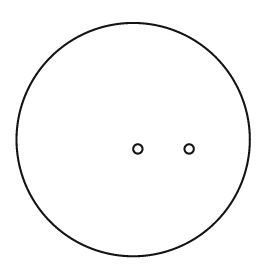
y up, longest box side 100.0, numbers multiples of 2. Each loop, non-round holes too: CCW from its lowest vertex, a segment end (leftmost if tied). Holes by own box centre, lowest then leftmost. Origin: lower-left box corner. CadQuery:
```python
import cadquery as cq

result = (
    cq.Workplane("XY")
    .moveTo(50.0, 50.0)
    .circle(50.0)
    .moveTo(52.0, 46.0)
    .circle(2.0)
    .moveTo(74.0, 46.0)
    .circle(2.0)
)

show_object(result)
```